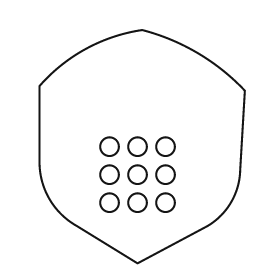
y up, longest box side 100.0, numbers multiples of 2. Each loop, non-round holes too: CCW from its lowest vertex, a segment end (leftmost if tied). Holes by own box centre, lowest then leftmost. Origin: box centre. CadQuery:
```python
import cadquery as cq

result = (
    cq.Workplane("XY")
    .moveTo(-2.0, -50.0)
    .lineTo(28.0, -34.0)
    .threePointArc((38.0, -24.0), (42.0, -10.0))
    .lineTo(44.0, 24.0)
    .threePointArc((24.0, 40.0), (0.0, 50.0))
    .threePointArc((-24.0, 42.0), (-44.0, 26.0))
    .lineTo(-44.0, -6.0)
    .threePointArc((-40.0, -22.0), (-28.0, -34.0))
    .close()
    .moveTo(-14.0, -24.0)
    .circle(4.0)
    .moveTo(-2.0, -24.0)
    .circle(4.0)
    .moveTo(10.0, -24.0)
    .circle(4.0)
    .moveTo(-14.0, -12.0)
    .circle(4.0)
    .moveTo(-2.0, -12.0)
    .circle(4.0)
    .moveTo(10.0, -12.0)
    .circle(4.0)
    .moveTo(-14.0, 0.0)
    .circle(4.0)
    .moveTo(-2.0, 0.0)
    .circle(4.0)
    .moveTo(10.0, 0.0)
    .circle(4.0)
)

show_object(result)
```